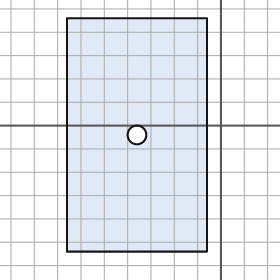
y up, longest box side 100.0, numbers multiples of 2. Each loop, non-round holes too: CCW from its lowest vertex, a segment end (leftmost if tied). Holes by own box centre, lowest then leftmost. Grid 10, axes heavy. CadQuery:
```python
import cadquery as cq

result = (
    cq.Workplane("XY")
    .moveTo(-66.0, -54.0)
    .lineTo(-6.0, -54.0)
    .lineTo(-6.0, 46.0)
    .lineTo(-66.0, 46.0)
    .close()
    .moveTo(-36.0, -4.0)
    .circle(4.0)
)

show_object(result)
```